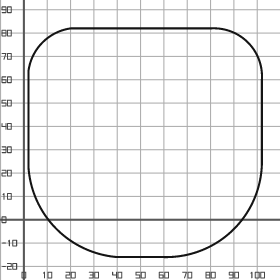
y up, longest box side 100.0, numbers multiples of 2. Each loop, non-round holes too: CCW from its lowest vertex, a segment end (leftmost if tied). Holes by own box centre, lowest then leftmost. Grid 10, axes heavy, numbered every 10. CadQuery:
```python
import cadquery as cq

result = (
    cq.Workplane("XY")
    .moveTo(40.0, -16.0)
    .lineTo(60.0, -16.0)
    .threePointArc((90.0, -4.0), (102.0, 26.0))
    .lineTo(102.0, 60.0)
    .threePointArc((96.0, 76.0), (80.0, 82.0))
    .lineTo(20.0, 82.0)
    .threePointArc((8.0, 76.0), (2.0, 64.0))
    .lineTo(2.0, 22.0)
    .threePointArc((14.0, -4.0), (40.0, -16.0))
    .close()
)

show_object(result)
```